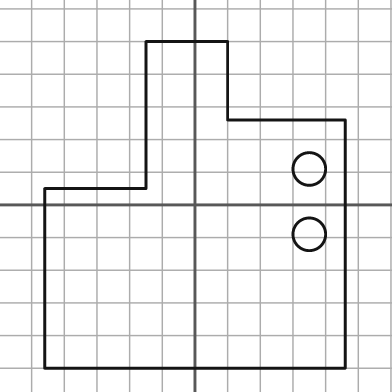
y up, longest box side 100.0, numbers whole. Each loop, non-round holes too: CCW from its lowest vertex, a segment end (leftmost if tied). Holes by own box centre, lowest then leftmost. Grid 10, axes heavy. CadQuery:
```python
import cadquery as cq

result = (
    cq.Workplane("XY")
    .moveTo(-46.0, -50.0)
    .lineTo(46.0, -50.0)
    .lineTo(46.0, 26.0)
    .lineTo(10.0, 26.0)
    .lineTo(10.0, 50.0)
    .lineTo(-15.0, 50.0)
    .lineTo(-15.0, 5.0)
    .lineTo(-46.0, 5.0)
    .close()
    .moveTo(35.0, -9.0)
    .circle(5.0)
    .moveTo(35.0, 11.0)
    .circle(5.0)
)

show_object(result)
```